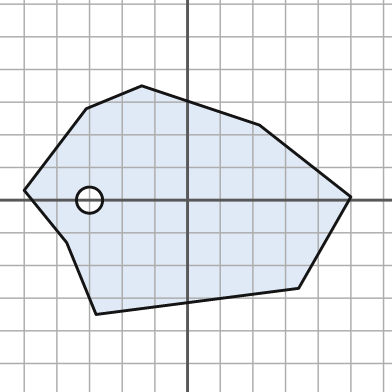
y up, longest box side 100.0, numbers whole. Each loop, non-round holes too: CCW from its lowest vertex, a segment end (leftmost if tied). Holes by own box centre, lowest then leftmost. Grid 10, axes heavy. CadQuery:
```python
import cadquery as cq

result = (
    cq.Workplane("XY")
    .moveTo(-28.0, -35.0)
    .lineTo(34.0, -27.0)
    .lineTo(50.0, 1.0)
    .lineTo(22.0, 23.0)
    .lineTo(-14.0, 35.0)
    .lineTo(-31.0, 28.0)
    .lineTo(-50.0, 3.0)
    .lineTo(-37.0, -13.0)
    .close()
    .moveTo(-30.0, 0.0)
    .circle(4.0)
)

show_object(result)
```